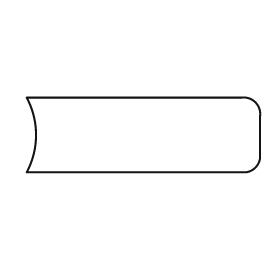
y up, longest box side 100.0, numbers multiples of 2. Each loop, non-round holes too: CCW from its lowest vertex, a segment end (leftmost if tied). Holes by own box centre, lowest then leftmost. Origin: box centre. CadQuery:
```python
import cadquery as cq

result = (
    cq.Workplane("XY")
    .moveTo(-50.0, -16.0)
    .lineTo(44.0, -16.0)
    .threePointArc((48.0, -14.0), (50.0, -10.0))
    .lineTo(50.0, 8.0)
    .threePointArc((48.0, 14.0), (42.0, 16.0))
    .lineTo(-50.0, 16.0)
    .threePointArc((-46.0, 0.0), (-50.0, -16.0))
    .close()
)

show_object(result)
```